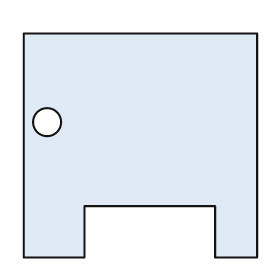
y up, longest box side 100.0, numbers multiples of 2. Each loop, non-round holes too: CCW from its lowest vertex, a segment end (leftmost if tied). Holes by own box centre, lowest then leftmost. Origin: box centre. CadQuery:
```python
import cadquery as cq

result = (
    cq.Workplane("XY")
    .moveTo(-50.0, -48.0)
    .lineTo(-24.0, -48.0)
    .lineTo(-24.0, -26.0)
    .lineTo(32.0, -26.0)
    .lineTo(32.0, -48.0)
    .lineTo(50.0, -48.0)
    .lineTo(50.0, 48.0)
    .lineTo(-50.0, 48.0)
    .close()
    .moveTo(-40.0, 10.0)
    .circle(6.0)
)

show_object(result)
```